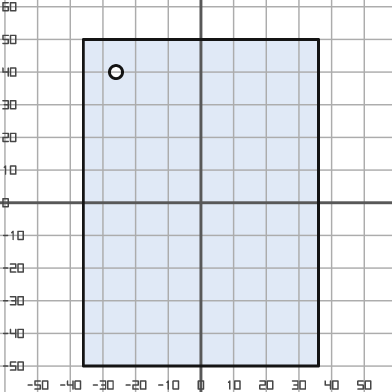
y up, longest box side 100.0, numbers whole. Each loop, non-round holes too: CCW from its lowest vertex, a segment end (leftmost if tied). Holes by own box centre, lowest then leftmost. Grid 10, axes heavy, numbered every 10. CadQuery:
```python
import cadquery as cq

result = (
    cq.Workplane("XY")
    .moveTo(-36.0, -50.0)
    .lineTo(36.0, -50.0)
    .lineTo(36.0, 50.0)
    .lineTo(-36.0, 50.0)
    .close()
    .moveTo(-26.0, 40.0)
    .circle(2.0)
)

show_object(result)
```